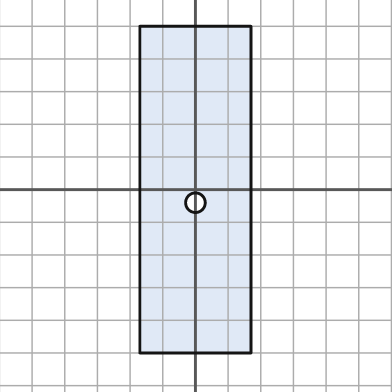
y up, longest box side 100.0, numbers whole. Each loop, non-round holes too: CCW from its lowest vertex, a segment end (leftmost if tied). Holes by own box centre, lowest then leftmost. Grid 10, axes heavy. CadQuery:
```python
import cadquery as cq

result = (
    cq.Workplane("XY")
    .moveTo(-17.0, -50.0)
    .lineTo(17.0, -50.0)
    .lineTo(17.0, 50.0)
    .lineTo(-17.0, 50.0)
    .close()
    .moveTo(0.0, -4.0)
    .circle(3.0)
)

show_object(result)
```